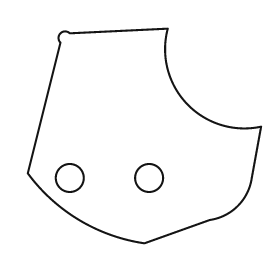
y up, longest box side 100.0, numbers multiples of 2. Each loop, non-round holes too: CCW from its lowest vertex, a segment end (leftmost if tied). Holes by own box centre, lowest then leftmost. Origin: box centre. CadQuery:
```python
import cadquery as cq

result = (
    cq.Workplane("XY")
    .moveTo(0.0, -46.0)
    .lineTo(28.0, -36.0)
    .threePointArc((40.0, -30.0), (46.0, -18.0))
    .lineTo(50.0, 4.0)
    .threePointArc((18.0, 14.0), (10.0, 46.0))
    .lineTo(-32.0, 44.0)
    .threePointArc((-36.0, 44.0), (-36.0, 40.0))
    .lineTo(-50.0, -16.0)
    .threePointArc((-28.0, -36.0), (0.0, -46.0))
    .close()
    .moveTo(-32.0, -18.0)
    .circle(6.0)
    .moveTo(2.0, -18.0)
    .circle(6.0)
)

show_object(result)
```